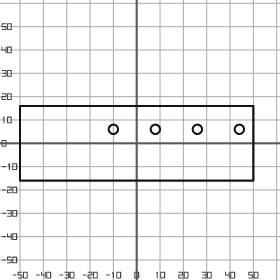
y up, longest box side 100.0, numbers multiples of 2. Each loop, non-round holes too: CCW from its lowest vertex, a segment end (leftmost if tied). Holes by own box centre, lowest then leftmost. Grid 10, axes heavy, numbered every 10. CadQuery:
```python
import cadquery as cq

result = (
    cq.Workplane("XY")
    .moveTo(-50.0, -16.0)
    .lineTo(50.0, -16.0)
    .lineTo(50.0, 16.0)
    .lineTo(-50.0, 16.0)
    .close()
    .moveTo(-10.0, 6.0)
    .circle(2.0)
    .moveTo(8.0, 6.0)
    .circle(2.0)
    .moveTo(26.0, 6.0)
    .circle(2.0)
    .moveTo(44.0, 6.0)
    .circle(2.0)
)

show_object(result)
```